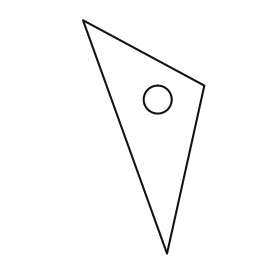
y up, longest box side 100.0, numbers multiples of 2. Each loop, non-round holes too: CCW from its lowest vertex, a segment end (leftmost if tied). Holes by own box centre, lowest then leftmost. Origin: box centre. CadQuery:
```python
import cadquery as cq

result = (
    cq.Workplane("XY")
    .moveTo(10.0, -50.0)
    .lineTo(26.0, 22.0)
    .lineTo(-26.0, 50.0)
    .close()
    .moveTo(6.0, 16.0)
    .circle(6.0)
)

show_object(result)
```